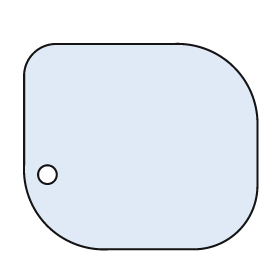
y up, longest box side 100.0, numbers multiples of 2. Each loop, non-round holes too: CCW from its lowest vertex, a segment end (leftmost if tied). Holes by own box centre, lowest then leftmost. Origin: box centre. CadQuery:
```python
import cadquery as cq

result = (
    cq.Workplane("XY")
    .moveTo(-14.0, -44.0)
    .lineTo(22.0, -44.0)
    .threePointArc((42.0, -36.0), (50.0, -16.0))
    .lineTo(50.0, 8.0)
    .threePointArc((40.0, 34.0), (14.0, 44.0))
    .lineTo(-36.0, 44.0)
    .threePointArc((-46.0, 40.0), (-50.0, 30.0))
    .lineTo(-50.0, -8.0)
    .threePointArc((-40.0, -34.0), (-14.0, -44.0))
    .close()
    .moveTo(-40.0, -12.0)
    .circle(4.0)
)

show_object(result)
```